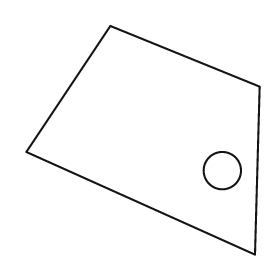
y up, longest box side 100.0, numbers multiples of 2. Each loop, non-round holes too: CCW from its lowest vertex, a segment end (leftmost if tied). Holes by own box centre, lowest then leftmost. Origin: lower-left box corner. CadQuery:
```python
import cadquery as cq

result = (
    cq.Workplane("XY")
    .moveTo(98.0, 0.0)
    .lineTo(100.0, 72.0)
    .lineTo(36.0, 98.0)
    .lineTo(0.0, 44.0)
    .close()
    .moveTo(84.0, 36.0)
    .circle(8.0)
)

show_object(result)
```